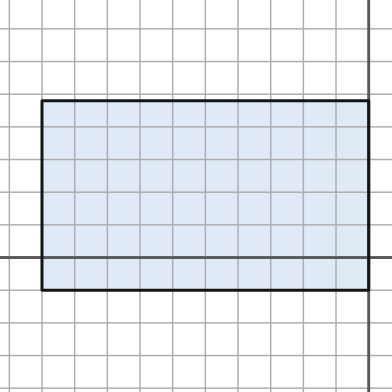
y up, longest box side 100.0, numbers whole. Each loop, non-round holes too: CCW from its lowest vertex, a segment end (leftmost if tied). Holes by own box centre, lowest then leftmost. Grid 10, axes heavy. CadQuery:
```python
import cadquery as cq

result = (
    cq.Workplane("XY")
    .moveTo(-100.0, -10.0)
    .lineTo(0.0, -10.0)
    .lineTo(0.0, 48.0)
    .lineTo(-100.0, 48.0)
    .close()
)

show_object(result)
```